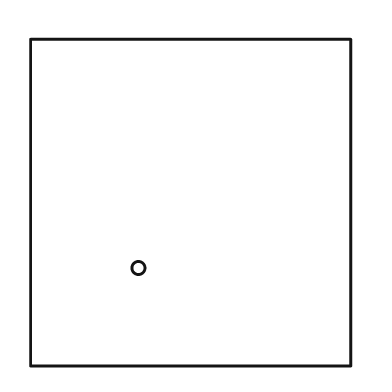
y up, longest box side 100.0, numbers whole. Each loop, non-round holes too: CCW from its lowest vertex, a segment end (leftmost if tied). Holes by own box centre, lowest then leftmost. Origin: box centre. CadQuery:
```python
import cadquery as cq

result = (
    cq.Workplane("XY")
    .moveTo(-49.0, -50.0)
    .lineTo(49.0, -50.0)
    .lineTo(49.0, 50.0)
    .lineTo(-49.0, 50.0)
    .close()
    .moveTo(-16.0, -20.0)
    .circle(2.0)
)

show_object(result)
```